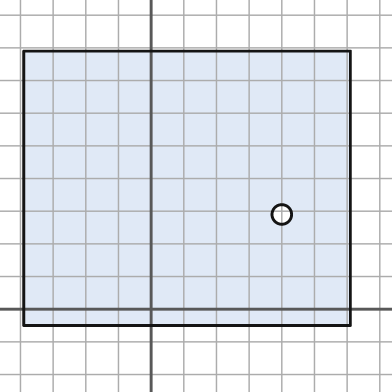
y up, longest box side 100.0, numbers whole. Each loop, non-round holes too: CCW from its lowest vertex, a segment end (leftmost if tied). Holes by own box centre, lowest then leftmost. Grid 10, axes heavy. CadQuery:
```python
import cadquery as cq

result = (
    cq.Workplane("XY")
    .moveTo(-39.0, -5.0)
    .lineTo(61.0, -5.0)
    .lineTo(61.0, 79.0)
    .lineTo(-39.0, 79.0)
    .close()
    .moveTo(40.0, 29.0)
    .circle(3.0)
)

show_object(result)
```